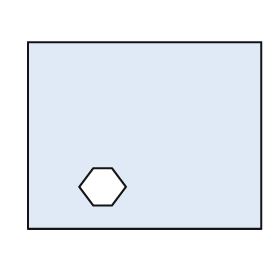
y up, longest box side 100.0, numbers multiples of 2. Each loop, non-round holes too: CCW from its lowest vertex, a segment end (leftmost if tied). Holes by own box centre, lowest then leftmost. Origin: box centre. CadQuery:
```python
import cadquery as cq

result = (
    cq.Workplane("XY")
    .moveTo(-50.0, -40.0)
    .lineTo(50.0, -40.0)
    .lineTo(50.0, 40.0)
    .lineTo(-50.0, 40.0)
    .close()
    .moveTo(-22.0, -30.0)
    .lineTo(-14.0, -30.0)
    .lineTo(-8.0, -22.0)
    .lineTo(-14.0, -14.0)
    .lineTo(-22.0, -14.0)
    .lineTo(-28.0, -22.0)
    .close()
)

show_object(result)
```